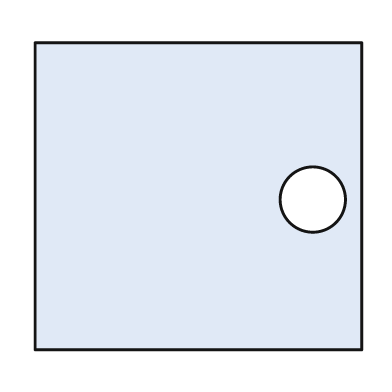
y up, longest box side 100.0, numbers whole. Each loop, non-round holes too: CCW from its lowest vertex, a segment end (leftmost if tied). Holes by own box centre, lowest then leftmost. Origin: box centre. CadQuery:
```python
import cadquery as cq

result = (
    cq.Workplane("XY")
    .moveTo(-50.0, -47.0)
    .lineTo(50.0, -47.0)
    .lineTo(50.0, 47.0)
    .lineTo(-50.0, 47.0)
    .close()
    .moveTo(35.0, -1.0)
    .circle(10.0)
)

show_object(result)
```